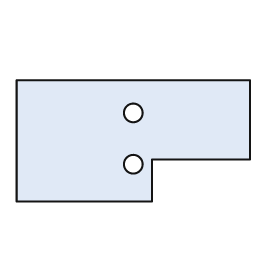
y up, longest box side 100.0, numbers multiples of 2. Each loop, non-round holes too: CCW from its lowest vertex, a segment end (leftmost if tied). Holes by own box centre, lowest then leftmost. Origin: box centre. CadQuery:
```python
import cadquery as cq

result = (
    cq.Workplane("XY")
    .moveTo(-50.0, -26.0)
    .lineTo(8.0, -26.0)
    .lineTo(8.0, -8.0)
    .lineTo(50.0, -8.0)
    .lineTo(50.0, 26.0)
    .lineTo(-50.0, 26.0)
    .close()
    .moveTo(0.0, -10.0)
    .circle(4.0)
    .moveTo(0.0, 12.0)
    .circle(4.0)
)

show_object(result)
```